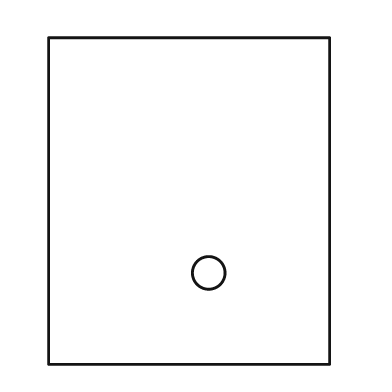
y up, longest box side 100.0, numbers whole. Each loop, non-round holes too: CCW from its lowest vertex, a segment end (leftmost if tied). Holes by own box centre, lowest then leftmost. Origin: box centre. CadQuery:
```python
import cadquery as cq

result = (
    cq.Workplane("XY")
    .moveTo(-43.0, -50.0)
    .lineTo(43.0, -50.0)
    .lineTo(43.0, 50.0)
    .lineTo(-43.0, 50.0)
    .close()
    .moveTo(6.0, -22.0)
    .circle(5.0)
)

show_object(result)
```